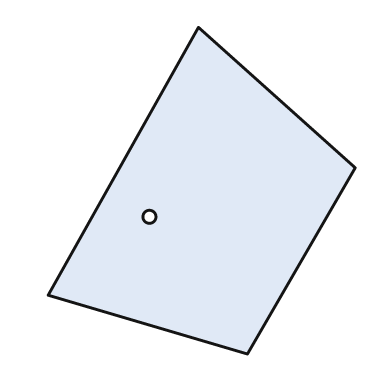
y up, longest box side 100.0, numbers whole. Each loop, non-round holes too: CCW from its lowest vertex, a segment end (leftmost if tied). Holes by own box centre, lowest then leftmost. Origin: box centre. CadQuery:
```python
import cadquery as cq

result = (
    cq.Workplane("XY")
    .moveTo(14.0, -50.0)
    .lineTo(47.0, 7.0)
    .lineTo(-1.0, 50.0)
    .lineTo(-47.0, -32.0)
    .close()
    .moveTo(-16.0, -8.0)
    .circle(2.0)
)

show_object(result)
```